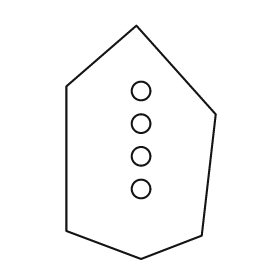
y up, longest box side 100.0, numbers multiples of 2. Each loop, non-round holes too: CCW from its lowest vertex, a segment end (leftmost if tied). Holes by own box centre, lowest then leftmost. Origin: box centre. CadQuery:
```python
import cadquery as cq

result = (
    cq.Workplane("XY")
    .moveTo(0.0, -50.0)
    .lineTo(26.0, -40.0)
    .lineTo(32.0, 12.0)
    .lineTo(-2.0, 50.0)
    .lineTo(-32.0, 24.0)
    .lineTo(-32.0, -38.0)
    .close()
    .moveTo(0.0, -20.0)
    .circle(4.0)
    .moveTo(0.0, -6.0)
    .circle(4.0)
    .moveTo(0.0, 8.0)
    .circle(4.0)
    .moveTo(0.0, 22.0)
    .circle(4.0)
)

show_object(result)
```